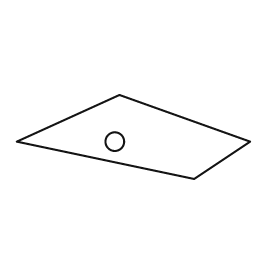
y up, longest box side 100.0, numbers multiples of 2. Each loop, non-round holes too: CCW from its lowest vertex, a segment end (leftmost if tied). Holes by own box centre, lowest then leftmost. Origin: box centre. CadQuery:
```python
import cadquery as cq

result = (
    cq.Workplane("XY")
    .moveTo(26.0, -18.0)
    .lineTo(50.0, -2.0)
    .lineTo(-6.0, 18.0)
    .lineTo(-50.0, -2.0)
    .close()
    .moveTo(-8.0, -2.0)
    .circle(4.0)
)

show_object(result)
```